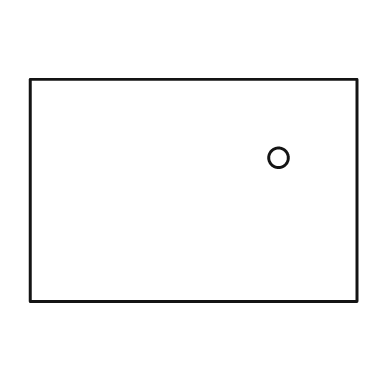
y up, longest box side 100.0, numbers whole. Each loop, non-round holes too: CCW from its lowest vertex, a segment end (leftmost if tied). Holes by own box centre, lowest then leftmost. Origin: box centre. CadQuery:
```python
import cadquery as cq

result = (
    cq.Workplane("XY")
    .moveTo(-50.0, -34.0)
    .lineTo(50.0, -34.0)
    .lineTo(50.0, 34.0)
    .lineTo(-50.0, 34.0)
    .close()
    .moveTo(26.0, 10.0)
    .circle(3.0)
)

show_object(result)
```